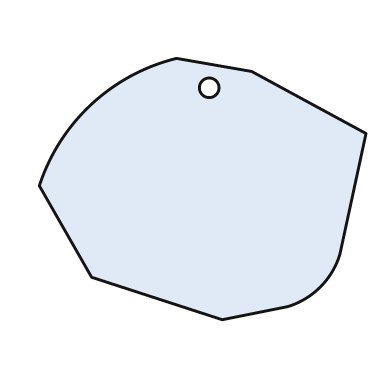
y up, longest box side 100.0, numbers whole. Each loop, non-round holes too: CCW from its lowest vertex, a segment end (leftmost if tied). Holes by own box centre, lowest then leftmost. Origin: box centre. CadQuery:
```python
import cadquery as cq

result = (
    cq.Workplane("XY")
    .moveTo(6.0, -40.0)
    .lineTo(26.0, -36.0)
    .threePointArc((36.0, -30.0), (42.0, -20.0))
    .lineTo(50.0, 17.0)
    .lineTo(15.0, 36.0)
    .lineTo(-8.0, 40.0)
    .threePointArc((-34.0, 26.0), (-50.0, 1.0))
    .lineTo(-34.0, -27.0)
    .close()
    .moveTo(2.0, 31.0)
    .circle(3.0)
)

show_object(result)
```